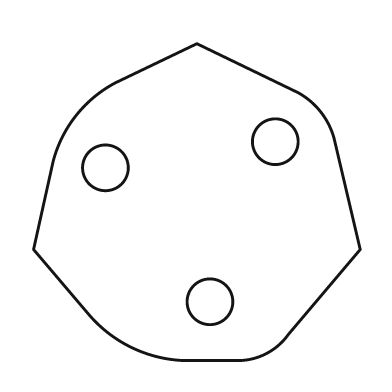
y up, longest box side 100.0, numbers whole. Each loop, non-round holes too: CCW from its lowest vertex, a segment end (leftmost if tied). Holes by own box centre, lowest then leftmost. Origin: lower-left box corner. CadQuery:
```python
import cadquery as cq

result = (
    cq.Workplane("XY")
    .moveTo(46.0, 0.0)
    .lineTo(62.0, 0.0)
    .threePointArc((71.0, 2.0), (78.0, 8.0))
    .lineTo(100.0, 34.0)
    .lineTo(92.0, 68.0)
    .threePointArc((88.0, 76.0), (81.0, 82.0))
    .lineTo(50.0, 97.0)
    .lineTo(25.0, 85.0)
    .threePointArc((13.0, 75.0), (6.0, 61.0))
    .lineTo(0.0, 34.0)
    .lineTo(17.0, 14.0)
    .threePointArc((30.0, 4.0), (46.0, 0.0))
    .close()
    .moveTo(54.0, 18.0)
    .circle(7.0)
    .moveTo(22.0, 59.0)
    .circle(7.0)
    .moveTo(74.0, 67.0)
    .circle(7.0)
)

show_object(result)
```